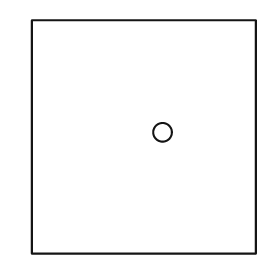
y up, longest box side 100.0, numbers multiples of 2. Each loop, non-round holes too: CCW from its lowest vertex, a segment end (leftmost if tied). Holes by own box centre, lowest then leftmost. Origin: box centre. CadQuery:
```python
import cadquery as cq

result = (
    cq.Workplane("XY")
    .moveTo(-48.0, -50.0)
    .lineTo(48.0, -50.0)
    .lineTo(48.0, 50.0)
    .lineTo(-48.0, 50.0)
    .close()
    .moveTo(8.0, 2.0)
    .circle(4.0)
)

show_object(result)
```